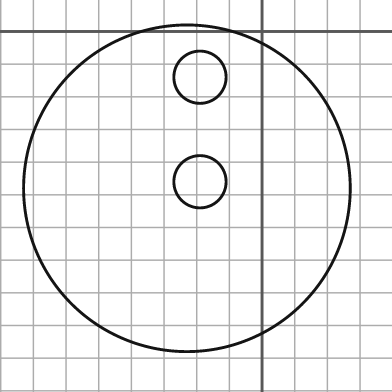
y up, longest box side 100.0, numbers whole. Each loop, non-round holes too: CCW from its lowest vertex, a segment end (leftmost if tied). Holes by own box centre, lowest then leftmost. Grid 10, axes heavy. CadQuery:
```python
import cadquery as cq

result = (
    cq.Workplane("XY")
    .moveTo(-23.0, -48.0)
    .circle(50.0)
    .moveTo(-19.0, -46.0)
    .circle(8.0)
    .moveTo(-19.0, -14.0)
    .circle(8.0)
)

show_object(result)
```